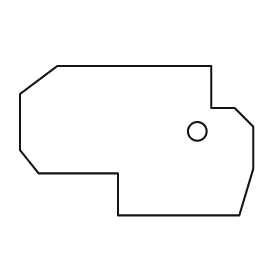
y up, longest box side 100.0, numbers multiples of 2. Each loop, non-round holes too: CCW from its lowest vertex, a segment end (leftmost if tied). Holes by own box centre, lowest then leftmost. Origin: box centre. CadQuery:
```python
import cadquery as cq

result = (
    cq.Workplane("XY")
    .moveTo(-8.0, -32.0)
    .lineTo(44.0, -32.0)
    .lineTo(50.0, -12.0)
    .lineTo(50.0, 6.0)
    .lineTo(42.0, 14.0)
    .lineTo(32.0, 14.0)
    .lineTo(32.0, 32.0)
    .lineTo(-34.0, 32.0)
    .lineTo(-50.0, 20.0)
    .lineTo(-50.0, -4.0)
    .lineTo(-42.0, -14.0)
    .lineTo(-8.0, -14.0)
    .close()
    .moveTo(26.0, 4.0)
    .circle(4.0)
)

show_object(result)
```